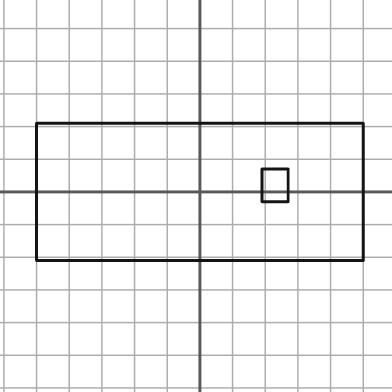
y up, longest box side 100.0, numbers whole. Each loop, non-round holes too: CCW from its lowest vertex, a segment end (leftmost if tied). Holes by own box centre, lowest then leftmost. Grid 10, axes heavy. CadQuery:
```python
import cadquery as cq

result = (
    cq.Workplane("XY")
    .moveTo(-50.0, -21.0)
    .lineTo(50.0, -21.0)
    .lineTo(50.0, 21.0)
    .lineTo(-50.0, 21.0)
    .close()
    .moveTo(19.0, -3.0)
    .lineTo(27.0, -3.0)
    .lineTo(27.0, 7.0)
    .lineTo(19.0, 7.0)
    .close()
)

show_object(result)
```